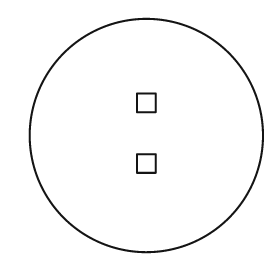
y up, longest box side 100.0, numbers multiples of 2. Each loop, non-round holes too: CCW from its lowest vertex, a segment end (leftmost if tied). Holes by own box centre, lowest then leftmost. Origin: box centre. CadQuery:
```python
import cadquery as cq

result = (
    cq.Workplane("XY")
    .moveTo(0.0, 0.0)
    .circle(50.0)
    .moveTo(-4.0, -16.0)
    .lineTo(4.0, -16.0)
    .lineTo(4.0, -8.0)
    .lineTo(-4.0, -8.0)
    .close()
    .moveTo(-4.0, 10.0)
    .lineTo(4.0, 10.0)
    .lineTo(4.0, 18.0)
    .lineTo(-4.0, 18.0)
    .close()
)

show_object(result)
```